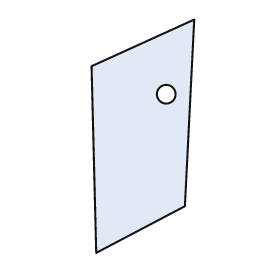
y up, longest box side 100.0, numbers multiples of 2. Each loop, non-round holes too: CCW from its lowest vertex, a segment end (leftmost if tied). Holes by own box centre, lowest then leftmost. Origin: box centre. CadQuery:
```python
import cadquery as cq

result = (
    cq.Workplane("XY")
    .moveTo(-20.0, -50.0)
    .lineTo(18.0, -30.0)
    .lineTo(22.0, 50.0)
    .lineTo(-22.0, 30.0)
    .close()
    .moveTo(10.0, 18.0)
    .circle(4.0)
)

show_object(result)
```